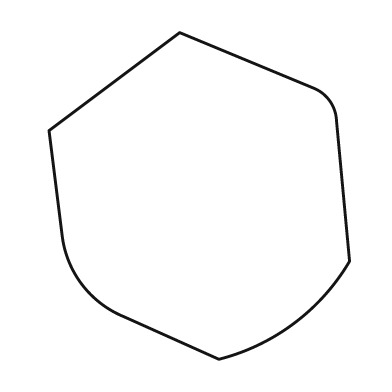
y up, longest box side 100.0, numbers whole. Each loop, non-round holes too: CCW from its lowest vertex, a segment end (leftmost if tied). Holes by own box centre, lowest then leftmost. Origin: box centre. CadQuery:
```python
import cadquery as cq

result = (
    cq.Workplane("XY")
    .moveTo(6.0, -50.0)
    .threePointArc((29.0, -39.0), (46.0, -20.0))
    .lineTo(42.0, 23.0)
    .threePointArc((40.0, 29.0), (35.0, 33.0))
    .lineTo(-6.0, 50.0)
    .lineTo(-46.0, 20.0)
    .lineTo(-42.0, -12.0)
    .threePointArc((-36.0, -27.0), (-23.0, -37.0))
    .close()
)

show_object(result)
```